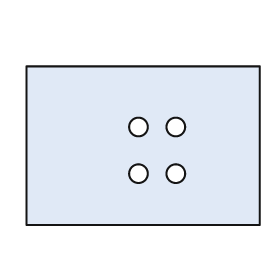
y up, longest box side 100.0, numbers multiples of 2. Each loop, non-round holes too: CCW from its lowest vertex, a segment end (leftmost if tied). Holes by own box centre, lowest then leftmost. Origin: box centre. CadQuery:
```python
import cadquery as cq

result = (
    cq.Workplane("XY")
    .moveTo(-50.0, -34.0)
    .lineTo(50.0, -34.0)
    .lineTo(50.0, 34.0)
    .lineTo(-50.0, 34.0)
    .close()
    .moveTo(-2.0, -12.0)
    .circle(4.0)
    .moveTo(14.0, -12.0)
    .circle(4.0)
    .moveTo(-2.0, 8.0)
    .circle(4.0)
    .moveTo(14.0, 8.0)
    .circle(4.0)
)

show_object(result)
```